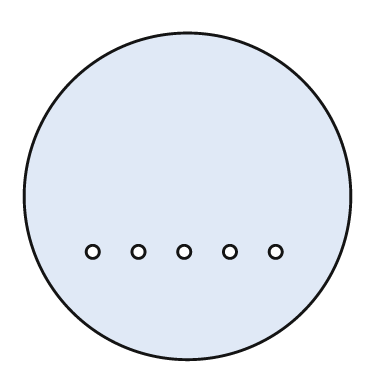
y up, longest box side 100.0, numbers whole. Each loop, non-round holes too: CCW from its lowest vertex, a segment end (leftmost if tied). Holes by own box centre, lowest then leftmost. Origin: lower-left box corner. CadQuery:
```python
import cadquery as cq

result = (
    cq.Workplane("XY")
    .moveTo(50.0, 50.0)
    .circle(50.0)
    .moveTo(21.0, 33.0)
    .circle(2.0)
    .moveTo(35.0, 33.0)
    .circle(2.0)
    .moveTo(49.0, 33.0)
    .circle(2.0)
    .moveTo(63.0, 33.0)
    .circle(2.0)
    .moveTo(77.0, 33.0)
    .circle(2.0)
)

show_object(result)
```